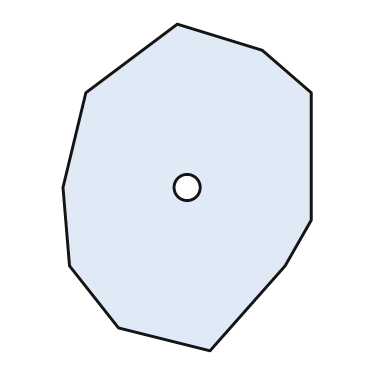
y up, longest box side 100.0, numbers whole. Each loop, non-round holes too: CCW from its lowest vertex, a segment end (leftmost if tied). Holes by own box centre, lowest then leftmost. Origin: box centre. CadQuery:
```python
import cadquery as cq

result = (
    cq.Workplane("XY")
    .moveTo(7.0, -50.0)
    .lineTo(30.0, -24.0)
    .lineTo(38.0, -10.0)
    .lineTo(38.0, 29.0)
    .lineTo(23.0, 42.0)
    .lineTo(-3.0, 50.0)
    .lineTo(-31.0, 29.0)
    .lineTo(-38.0, 0.0)
    .lineTo(-36.0, -24.0)
    .lineTo(-21.0, -43.0)
    .close()
    .moveTo(0.0, 0.0)
    .circle(4.0)
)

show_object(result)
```